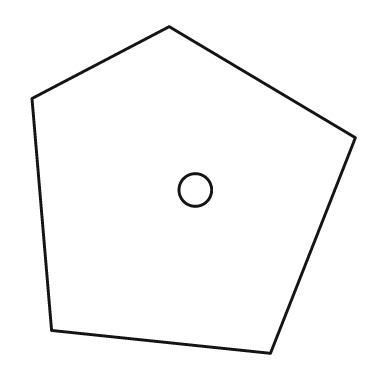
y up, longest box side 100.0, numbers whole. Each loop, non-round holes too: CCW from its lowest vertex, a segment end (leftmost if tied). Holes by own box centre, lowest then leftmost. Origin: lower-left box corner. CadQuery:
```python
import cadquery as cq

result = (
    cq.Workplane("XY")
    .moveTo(73.0, 0.0)
    .lineTo(99.0, 66.0)
    .lineTo(42.0, 100.0)
    .lineTo(0.0, 78.0)
    .lineTo(6.0, 7.0)
    .close()
    .moveTo(50.0, 50.0)
    .circle(5.0)
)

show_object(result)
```